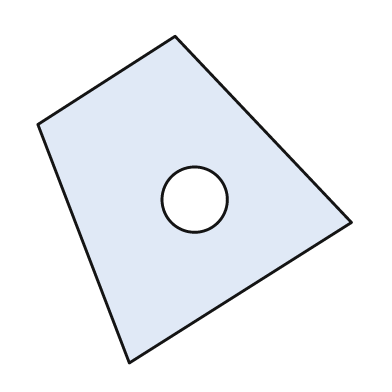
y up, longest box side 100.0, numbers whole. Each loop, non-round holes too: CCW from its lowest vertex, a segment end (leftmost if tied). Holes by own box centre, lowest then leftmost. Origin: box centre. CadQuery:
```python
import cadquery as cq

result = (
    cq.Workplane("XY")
    .moveTo(-20.0, -50.0)
    .lineTo(48.0, -7.0)
    .lineTo(-6.0, 50.0)
    .lineTo(-48.0, 23.0)
    .close()
    .moveTo(0.0, 0.0)
    .circle(10.0)
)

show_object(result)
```